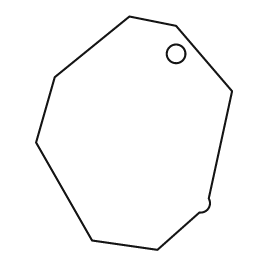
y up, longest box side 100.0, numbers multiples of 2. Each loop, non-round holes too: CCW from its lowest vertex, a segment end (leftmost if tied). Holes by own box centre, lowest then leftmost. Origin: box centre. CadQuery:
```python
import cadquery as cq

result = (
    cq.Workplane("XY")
    .moveTo(10.0, -50.0)
    .lineTo(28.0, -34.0)
    .threePointArc((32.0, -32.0), (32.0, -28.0))
    .lineTo(42.0, 18.0)
    .lineTo(18.0, 46.0)
    .lineTo(-2.0, 50.0)
    .lineTo(-34.0, 24.0)
    .lineTo(-42.0, -4.0)
    .lineTo(-18.0, -46.0)
    .close()
    .moveTo(18.0, 34.0)
    .circle(4.0)
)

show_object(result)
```